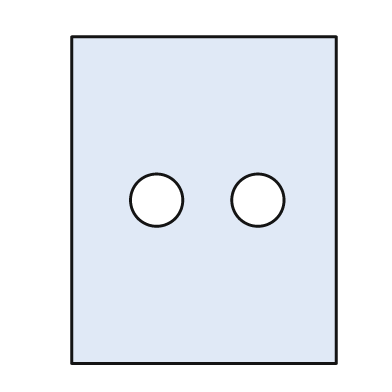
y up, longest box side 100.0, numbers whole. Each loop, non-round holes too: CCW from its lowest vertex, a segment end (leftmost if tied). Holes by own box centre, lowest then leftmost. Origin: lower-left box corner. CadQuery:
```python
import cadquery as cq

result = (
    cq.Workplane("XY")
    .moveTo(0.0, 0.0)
    .lineTo(81.0, 0.0)
    .lineTo(81.0, 100.0)
    .lineTo(0.0, 100.0)
    .close()
    .moveTo(26.0, 50.0)
    .circle(8.0)
    .moveTo(57.0, 50.0)
    .circle(8.0)
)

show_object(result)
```